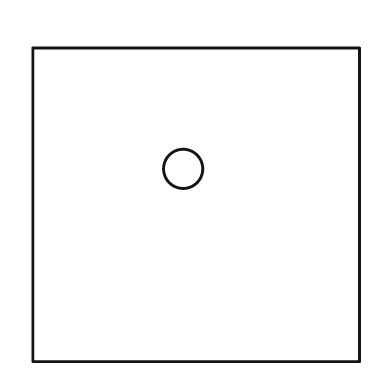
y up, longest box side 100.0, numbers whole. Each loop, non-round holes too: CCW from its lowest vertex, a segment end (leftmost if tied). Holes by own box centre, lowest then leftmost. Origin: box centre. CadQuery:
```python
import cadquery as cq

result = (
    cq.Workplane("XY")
    .moveTo(-50.0, -48.0)
    .lineTo(50.0, -48.0)
    .lineTo(50.0, 48.0)
    .lineTo(-50.0, 48.0)
    .close()
    .moveTo(-4.0, 11.0)
    .circle(6.0)
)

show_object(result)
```